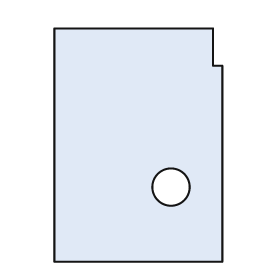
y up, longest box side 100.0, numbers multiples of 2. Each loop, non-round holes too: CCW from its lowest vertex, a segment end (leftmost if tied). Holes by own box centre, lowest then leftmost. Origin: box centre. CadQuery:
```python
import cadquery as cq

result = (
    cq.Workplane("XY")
    .moveTo(-36.0, -50.0)
    .lineTo(36.0, -50.0)
    .lineTo(36.0, 34.0)
    .lineTo(32.0, 34.0)
    .lineTo(32.0, 50.0)
    .lineTo(-36.0, 50.0)
    .close()
    .moveTo(14.0, -18.0)
    .circle(8.0)
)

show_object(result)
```